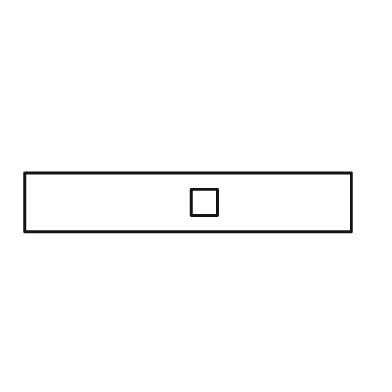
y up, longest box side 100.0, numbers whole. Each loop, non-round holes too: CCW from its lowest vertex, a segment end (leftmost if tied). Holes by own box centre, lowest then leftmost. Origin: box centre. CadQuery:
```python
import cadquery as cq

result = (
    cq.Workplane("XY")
    .moveTo(-50.0, -9.0)
    .lineTo(50.0, -9.0)
    .lineTo(50.0, 9.0)
    .lineTo(-50.0, 9.0)
    .close()
    .moveTo(1.0, -4.0)
    .lineTo(9.0, -4.0)
    .lineTo(9.0, 4.0)
    .lineTo(1.0, 4.0)
    .close()
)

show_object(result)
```